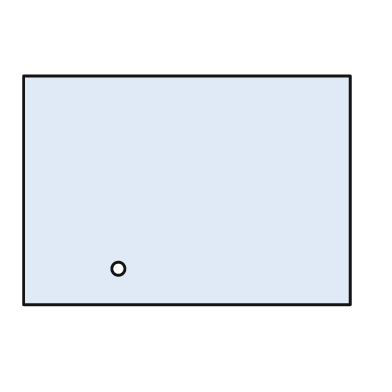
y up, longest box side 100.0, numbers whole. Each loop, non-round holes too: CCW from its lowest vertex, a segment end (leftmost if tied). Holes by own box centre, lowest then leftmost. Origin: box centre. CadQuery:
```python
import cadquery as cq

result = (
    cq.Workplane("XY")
    .moveTo(-50.0, -35.0)
    .lineTo(50.0, -35.0)
    .lineTo(50.0, 35.0)
    .lineTo(-50.0, 35.0)
    .close()
    .moveTo(-21.0, -24.0)
    .circle(2.0)
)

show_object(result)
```